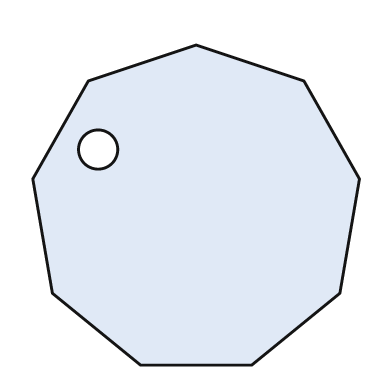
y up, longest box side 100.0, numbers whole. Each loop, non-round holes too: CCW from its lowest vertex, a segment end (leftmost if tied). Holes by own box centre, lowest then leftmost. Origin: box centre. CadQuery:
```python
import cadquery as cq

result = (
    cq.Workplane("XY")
    .moveTo(-17.0, -49.0)
    .lineTo(17.0, -49.0)
    .lineTo(44.0, -27.0)
    .lineTo(50.0, 8.0)
    .lineTo(33.0, 38.0)
    .lineTo(0.0, 49.0)
    .lineTo(-33.0, 38.0)
    .lineTo(-50.0, 8.0)
    .lineTo(-44.0, -27.0)
    .close()
    .moveTo(-30.0, 17.0)
    .circle(6.0)
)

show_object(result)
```